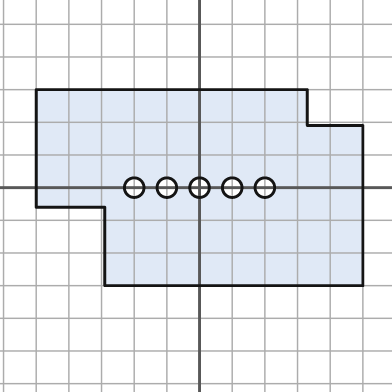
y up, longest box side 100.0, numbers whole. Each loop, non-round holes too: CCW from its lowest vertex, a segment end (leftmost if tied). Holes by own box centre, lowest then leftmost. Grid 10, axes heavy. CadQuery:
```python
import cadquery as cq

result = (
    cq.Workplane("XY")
    .moveTo(-29.0, -30.0)
    .lineTo(50.0, -30.0)
    .lineTo(50.0, 19.0)
    .lineTo(33.0, 19.0)
    .lineTo(33.0, 30.0)
    .lineTo(-50.0, 30.0)
    .lineTo(-50.0, -6.0)
    .lineTo(-29.0, -6.0)
    .close()
    .moveTo(-20.0, 0.0)
    .circle(3.0)
    .moveTo(-10.0, 0.0)
    .circle(3.0)
    .moveTo(0.0, 0.0)
    .circle(3.0)
    .moveTo(10.0, 0.0)
    .circle(3.0)
    .moveTo(20.0, 0.0)
    .circle(3.0)
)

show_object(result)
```